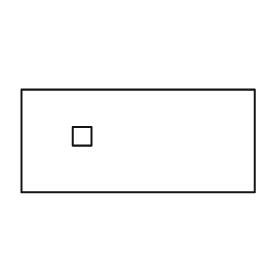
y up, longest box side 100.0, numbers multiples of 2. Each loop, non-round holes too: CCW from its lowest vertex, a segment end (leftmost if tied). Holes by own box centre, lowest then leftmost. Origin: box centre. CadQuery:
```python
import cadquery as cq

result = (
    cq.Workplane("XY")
    .moveTo(-50.0, -22.0)
    .lineTo(50.0, -22.0)
    .lineTo(50.0, 22.0)
    .lineTo(-50.0, 22.0)
    .close()
    .moveTo(-28.0, -2.0)
    .lineTo(-20.0, -2.0)
    .lineTo(-20.0, 6.0)
    .lineTo(-28.0, 6.0)
    .close()
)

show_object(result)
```